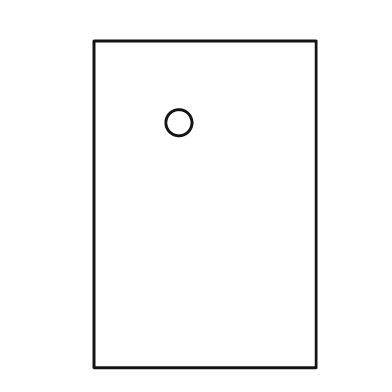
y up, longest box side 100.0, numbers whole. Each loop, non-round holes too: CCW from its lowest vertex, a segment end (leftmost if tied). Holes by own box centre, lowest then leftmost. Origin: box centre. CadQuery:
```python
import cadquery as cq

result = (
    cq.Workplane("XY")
    .moveTo(-34.0, -50.0)
    .lineTo(34.0, -50.0)
    .lineTo(34.0, 50.0)
    .lineTo(-34.0, 50.0)
    .close()
    .moveTo(-8.0, 25.0)
    .circle(4.0)
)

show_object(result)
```